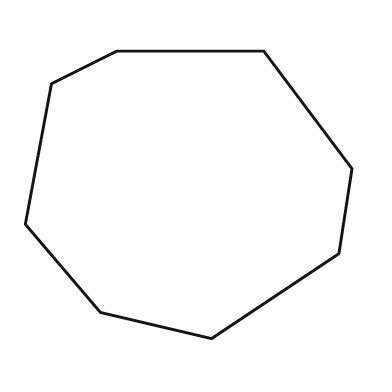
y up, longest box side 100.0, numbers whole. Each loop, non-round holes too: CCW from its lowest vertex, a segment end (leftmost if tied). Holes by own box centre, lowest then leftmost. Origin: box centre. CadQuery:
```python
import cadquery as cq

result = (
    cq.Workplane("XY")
    .moveTo(7.0, -44.0)
    .lineTo(46.0, -18.0)
    .lineTo(50.0, 8.0)
    .lineTo(23.0, 44.0)
    .lineTo(-22.0, 44.0)
    .lineTo(-42.0, 34.0)
    .lineTo(-50.0, -9.0)
    .lineTo(-27.0, -36.0)
    .close()
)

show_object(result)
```